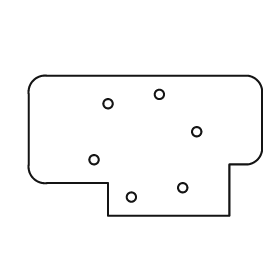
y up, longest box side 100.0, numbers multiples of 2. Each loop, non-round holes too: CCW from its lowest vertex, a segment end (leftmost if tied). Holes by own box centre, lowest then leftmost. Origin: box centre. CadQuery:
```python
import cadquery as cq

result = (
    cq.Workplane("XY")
    .moveTo(-16.0, -30.0)
    .lineTo(36.0, -30.0)
    .lineTo(36.0, -8.0)
    .lineTo(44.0, -8.0)
    .threePointArc((48.0, -6.0), (50.0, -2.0))
    .lineTo(50.0, 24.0)
    .threePointArc((48.0, 28.0), (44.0, 30.0))
    .lineTo(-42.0, 30.0)
    .threePointArc((-48.0, 28.0), (-50.0, 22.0))
    .lineTo(-50.0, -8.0)
    .threePointArc((-48.0, -14.0), (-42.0, -16.0))
    .lineTo(-16.0, -16.0)
    .close()
    .moveTo(-6.0, -22.0)
    .circle(2.0)
    .moveTo(16.0, -18.0)
    .circle(2.0)
    .moveTo(-22.0, -6.0)
    .circle(2.0)
    .moveTo(22.0, 6.0)
    .circle(2.0)
    .moveTo(-16.0, 18.0)
    .circle(2.0)
    .moveTo(6.0, 22.0)
    .circle(2.0)
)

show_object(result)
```